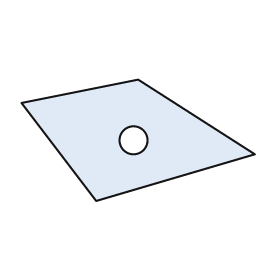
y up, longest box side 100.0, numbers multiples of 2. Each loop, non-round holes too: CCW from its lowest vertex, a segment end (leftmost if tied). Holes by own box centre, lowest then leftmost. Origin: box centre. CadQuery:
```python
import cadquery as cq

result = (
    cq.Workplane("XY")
    .moveTo(-18.0, -26.0)
    .lineTo(50.0, -6.0)
    .lineTo(0.0, 26.0)
    .lineTo(-50.0, 16.0)
    .close()
    .moveTo(-2.0, 0.0)
    .circle(6.0)
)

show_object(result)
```